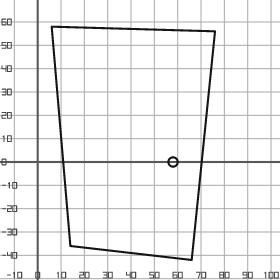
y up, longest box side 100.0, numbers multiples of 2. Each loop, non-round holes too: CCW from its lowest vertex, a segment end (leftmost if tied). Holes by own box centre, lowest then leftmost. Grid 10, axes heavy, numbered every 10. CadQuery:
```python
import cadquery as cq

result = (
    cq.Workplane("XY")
    .moveTo(66.0, -42.0)
    .lineTo(76.0, 56.0)
    .lineTo(6.0, 58.0)
    .lineTo(14.0, -36.0)
    .close()
    .moveTo(58.0, 0.0)
    .circle(2.0)
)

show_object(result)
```